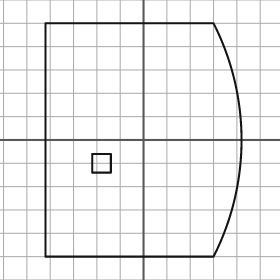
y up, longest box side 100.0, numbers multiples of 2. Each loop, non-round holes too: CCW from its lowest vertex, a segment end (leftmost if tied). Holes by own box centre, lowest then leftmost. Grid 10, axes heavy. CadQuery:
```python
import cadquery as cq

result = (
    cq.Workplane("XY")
    .moveTo(-42.0, -50.0)
    .lineTo(30.0, -50.0)
    .threePointArc((42.0, 0.0), (30.0, 50.0))
    .lineTo(-42.0, 50.0)
    .close()
    .moveTo(-22.0, -14.0)
    .lineTo(-14.0, -14.0)
    .lineTo(-14.0, -6.0)
    .lineTo(-22.0, -6.0)
    .close()
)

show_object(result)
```